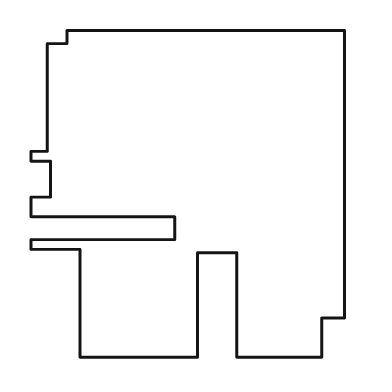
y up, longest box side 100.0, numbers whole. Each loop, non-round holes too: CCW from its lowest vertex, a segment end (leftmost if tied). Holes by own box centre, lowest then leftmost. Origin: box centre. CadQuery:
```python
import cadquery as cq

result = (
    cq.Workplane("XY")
    .moveTo(-33.0, -50.0)
    .lineTo(3.0, -50.0)
    .lineTo(3.0, -18.0)
    .lineTo(15.0, -18.0)
    .lineTo(15.0, -50.0)
    .lineTo(41.0, -50.0)
    .lineTo(41.0, -38.0)
    .lineTo(48.0, -38.0)
    .lineTo(48.0, 50.0)
    .lineTo(-37.0, 50.0)
    .lineTo(-37.0, 46.0)
    .lineTo(-43.0, 46.0)
    .lineTo(-43.0, 13.0)
    .lineTo(-48.0, 13.0)
    .lineTo(-48.0, 10.0)
    .lineTo(-42.0, 10.0)
    .lineTo(-42.0, -1.0)
    .lineTo(-48.0, -1.0)
    .lineTo(-48.0, -7.0)
    .lineTo(-4.0, -7.0)
    .lineTo(-4.0, -14.0)
    .lineTo(-48.0, -14.0)
    .lineTo(-48.0, -17.0)
    .lineTo(-33.0, -17.0)
    .close()
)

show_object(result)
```